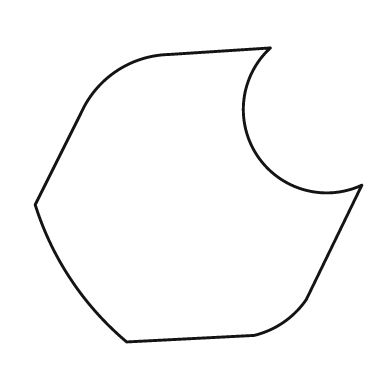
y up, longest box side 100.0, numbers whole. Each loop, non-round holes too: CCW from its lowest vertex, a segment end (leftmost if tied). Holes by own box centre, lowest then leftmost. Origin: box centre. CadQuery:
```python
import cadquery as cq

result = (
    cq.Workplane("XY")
    .moveTo(-22.0, -45.0)
    .lineTo(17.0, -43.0)
    .threePointArc((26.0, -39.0), (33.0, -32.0))
    .lineTo(50.0, 3.0)
    .threePointArc((18.0, 12.0), (22.0, 45.0))
    .lineTo(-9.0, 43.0)
    .threePointArc((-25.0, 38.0), (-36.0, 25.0))
    .lineTo(-50.0, -3.0)
    .threePointArc((-39.0, -26.0), (-22.0, -45.0))
    .close()
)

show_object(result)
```